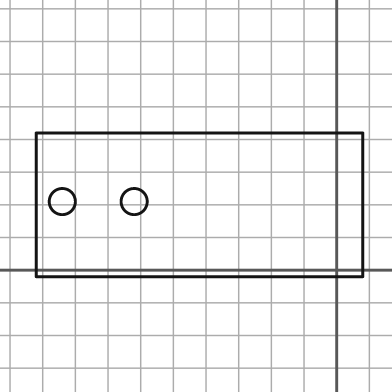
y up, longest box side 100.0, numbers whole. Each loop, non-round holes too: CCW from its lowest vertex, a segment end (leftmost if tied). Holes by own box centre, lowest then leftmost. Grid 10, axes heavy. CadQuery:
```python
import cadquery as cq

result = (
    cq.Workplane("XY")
    .moveTo(-92.0, -2.0)
    .lineTo(8.0, -2.0)
    .lineTo(8.0, 42.0)
    .lineTo(-92.0, 42.0)
    .close()
    .moveTo(-84.0, 21.0)
    .circle(4.0)
    .moveTo(-62.0, 21.0)
    .circle(4.0)
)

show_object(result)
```